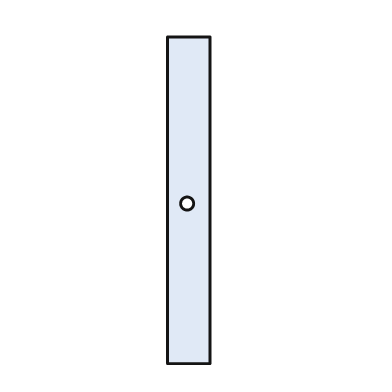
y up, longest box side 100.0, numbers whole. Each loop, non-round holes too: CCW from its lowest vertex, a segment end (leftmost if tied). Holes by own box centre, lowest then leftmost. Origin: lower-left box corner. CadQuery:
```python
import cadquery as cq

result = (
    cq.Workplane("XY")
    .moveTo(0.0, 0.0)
    .lineTo(13.0, 0.0)
    .lineTo(13.0, 100.0)
    .lineTo(0.0, 100.0)
    .close()
    .moveTo(6.0, 49.0)
    .circle(2.0)
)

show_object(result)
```